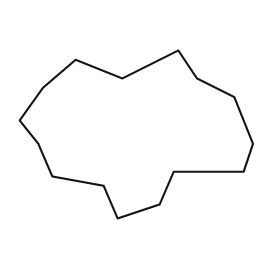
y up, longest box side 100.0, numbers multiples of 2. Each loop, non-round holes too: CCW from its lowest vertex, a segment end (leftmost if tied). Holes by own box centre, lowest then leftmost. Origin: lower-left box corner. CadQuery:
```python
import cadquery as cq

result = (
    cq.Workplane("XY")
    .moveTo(42.0, 0.0)
    .lineTo(60.0, 6.0)
    .lineTo(66.0, 20.0)
    .lineTo(96.0, 20.0)
    .lineTo(100.0, 32.0)
    .lineTo(92.0, 52.0)
    .lineTo(76.0, 60.0)
    .lineTo(68.0, 72.0)
    .lineTo(44.0, 60.0)
    .lineTo(24.0, 68.0)
    .lineTo(10.0, 56.0)
    .lineTo(0.0, 42.0)
    .lineTo(8.0, 32.0)
    .lineTo(14.0, 18.0)
    .lineTo(36.0, 14.0)
    .close()
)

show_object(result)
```